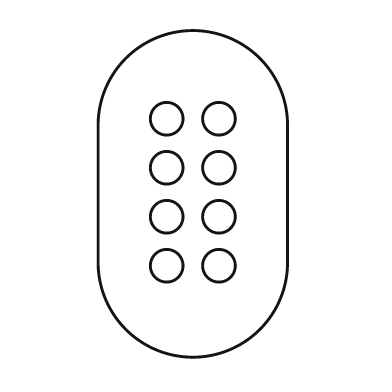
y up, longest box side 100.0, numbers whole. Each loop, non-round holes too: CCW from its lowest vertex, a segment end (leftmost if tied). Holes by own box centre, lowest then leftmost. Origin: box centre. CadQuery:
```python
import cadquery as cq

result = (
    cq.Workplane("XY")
    .moveTo(-29.0, -21.0)
    .threePointArc((0.0, -50.0), (29.0, -21.0))
    .lineTo(29.0, 21.0)
    .threePointArc((0.0, 50.0), (-29.0, 21.0))
    .close()
    .moveTo(-8.0, -22.0)
    .circle(5.0)
    .moveTo(8.0, -22.0)
    .circle(5.0)
    .moveTo(-8.0, -7.0)
    .circle(5.0)
    .moveTo(8.0, -7.0)
    .circle(5.0)
    .moveTo(-8.0, 8.0)
    .circle(5.0)
    .moveTo(8.0, 8.0)
    .circle(5.0)
    .moveTo(-8.0, 23.0)
    .circle(5.0)
    .moveTo(8.0, 23.0)
    .circle(5.0)
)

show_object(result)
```